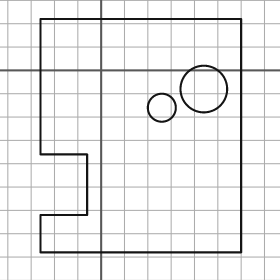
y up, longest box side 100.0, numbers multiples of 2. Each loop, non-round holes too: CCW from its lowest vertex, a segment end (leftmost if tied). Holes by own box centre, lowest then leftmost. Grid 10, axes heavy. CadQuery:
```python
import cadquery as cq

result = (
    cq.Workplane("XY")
    .moveTo(-26.0, -78.0)
    .lineTo(60.0, -78.0)
    .lineTo(60.0, 22.0)
    .lineTo(-26.0, 22.0)
    .lineTo(-26.0, -36.0)
    .lineTo(-6.0, -36.0)
    .lineTo(-6.0, -62.0)
    .lineTo(-26.0, -62.0)
    .close()
    .moveTo(26.0, -16.0)
    .circle(6.0)
    .moveTo(44.0, -8.0)
    .circle(10.0)
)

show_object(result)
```